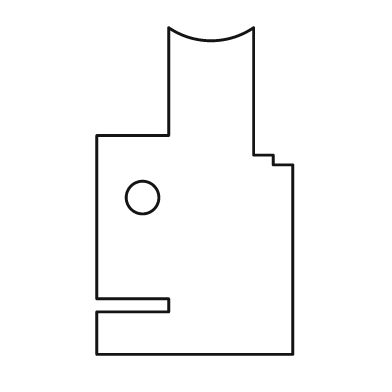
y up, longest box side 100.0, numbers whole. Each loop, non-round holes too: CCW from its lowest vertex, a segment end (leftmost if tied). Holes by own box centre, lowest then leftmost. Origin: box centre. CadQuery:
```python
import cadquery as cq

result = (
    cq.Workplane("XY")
    .moveTo(-30.0, -50.0)
    .lineTo(30.0, -50.0)
    .lineTo(30.0, 8.0)
    .lineTo(24.0, 8.0)
    .lineTo(24.0, 11.0)
    .lineTo(18.0, 11.0)
    .lineTo(18.0, 50.0)
    .threePointArc((5.0, 46.0), (-8.0, 50.0))
    .lineTo(-8.0, 17.0)
    .lineTo(-30.0, 17.0)
    .lineTo(-30.0, -33.0)
    .lineTo(-8.0, -33.0)
    .lineTo(-8.0, -37.0)
    .lineTo(-30.0, -37.0)
    .close()
    .moveTo(-16.0, -2.0)
    .circle(5.0)
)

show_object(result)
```